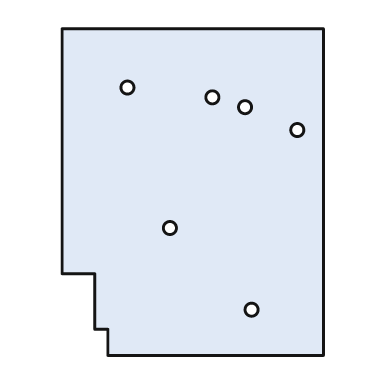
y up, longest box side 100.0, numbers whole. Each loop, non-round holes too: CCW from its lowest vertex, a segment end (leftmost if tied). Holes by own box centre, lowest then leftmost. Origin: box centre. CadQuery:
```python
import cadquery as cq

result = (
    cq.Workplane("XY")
    .moveTo(-26.0, -50.0)
    .lineTo(40.0, -50.0)
    .lineTo(40.0, 50.0)
    .lineTo(-40.0, 50.0)
    .lineTo(-40.0, -25.0)
    .lineTo(-30.0, -25.0)
    .lineTo(-30.0, -42.0)
    .lineTo(-26.0, -42.0)
    .close()
    .moveTo(18.0, -36.0)
    .circle(2.0)
    .moveTo(-7.0, -11.0)
    .circle(2.0)
    .moveTo(32.0, 19.0)
    .circle(2.0)
    .moveTo(16.0, 26.0)
    .circle(2.0)
    .moveTo(6.0, 29.0)
    .circle(2.0)
    .moveTo(-20.0, 32.0)
    .circle(2.0)
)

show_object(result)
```